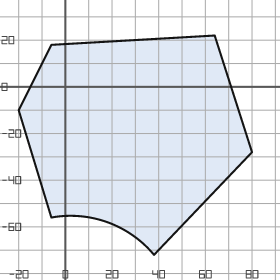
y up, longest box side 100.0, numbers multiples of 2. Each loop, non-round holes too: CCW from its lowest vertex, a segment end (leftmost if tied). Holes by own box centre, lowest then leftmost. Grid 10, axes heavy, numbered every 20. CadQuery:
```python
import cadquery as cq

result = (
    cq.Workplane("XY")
    .moveTo(38.0, -72.0)
    .lineTo(80.0, -28.0)
    .lineTo(64.0, 22.0)
    .lineTo(-6.0, 18.0)
    .lineTo(-20.0, -10.0)
    .lineTo(-6.0, -56.0)
    .threePointArc((18.0, -58.0), (38.0, -72.0))
    .close()
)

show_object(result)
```